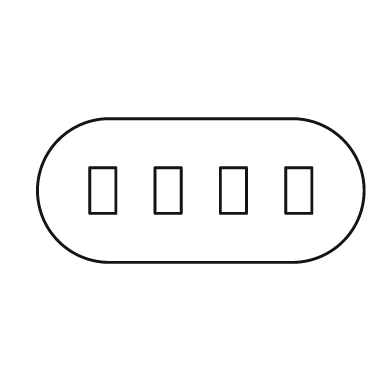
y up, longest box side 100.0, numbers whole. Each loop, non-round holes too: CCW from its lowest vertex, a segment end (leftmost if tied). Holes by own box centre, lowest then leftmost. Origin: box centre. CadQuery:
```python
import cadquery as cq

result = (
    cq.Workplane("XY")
    .moveTo(-28.0, -22.0)
    .lineTo(28.0, -22.0)
    .threePointArc((50.0, 0.0), (28.0, 22.0))
    .lineTo(-28.0, 22.0)
    .threePointArc((-50.0, 0.0), (-28.0, -22.0))
    .close()
    .moveTo(-34.0, -7.0)
    .lineTo(-26.0, -7.0)
    .lineTo(-26.0, 7.0)
    .lineTo(-34.0, 7.0)
    .close()
    .moveTo(-14.0, -7.0)
    .lineTo(-6.0, -7.0)
    .lineTo(-6.0, 7.0)
    .lineTo(-14.0, 7.0)
    .close()
    .moveTo(6.0, -7.0)
    .lineTo(14.0, -7.0)
    .lineTo(14.0, 7.0)
    .lineTo(6.0, 7.0)
    .close()
    .moveTo(26.0, -7.0)
    .lineTo(34.0, -7.0)
    .lineTo(34.0, 7.0)
    .lineTo(26.0, 7.0)
    .close()
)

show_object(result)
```